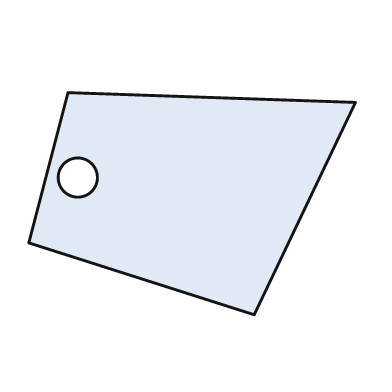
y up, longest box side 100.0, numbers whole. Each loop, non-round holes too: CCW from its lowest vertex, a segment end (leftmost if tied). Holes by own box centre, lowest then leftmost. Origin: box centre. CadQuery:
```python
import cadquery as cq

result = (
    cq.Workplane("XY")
    .moveTo(19.0, -34.0)
    .lineTo(50.0, 31.0)
    .lineTo(-38.0, 34.0)
    .lineTo(-50.0, -12.0)
    .close()
    .moveTo(-35.0, 8.0)
    .circle(6.0)
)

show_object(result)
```